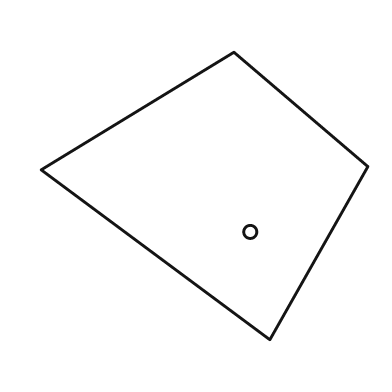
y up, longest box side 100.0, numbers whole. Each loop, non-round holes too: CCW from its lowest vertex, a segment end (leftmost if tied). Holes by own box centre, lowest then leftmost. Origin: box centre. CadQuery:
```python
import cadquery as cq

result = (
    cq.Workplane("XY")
    .moveTo(20.0, -44.0)
    .lineTo(50.0, 9.0)
    .lineTo(9.0, 44.0)
    .lineTo(-50.0, 8.0)
    .close()
    .moveTo(14.0, -11.0)
    .circle(2.0)
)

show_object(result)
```